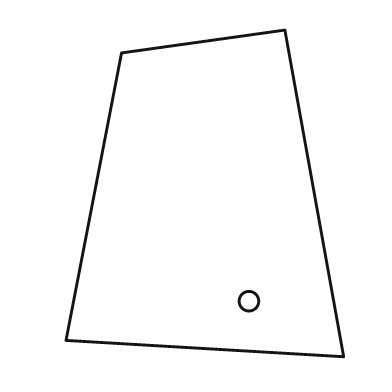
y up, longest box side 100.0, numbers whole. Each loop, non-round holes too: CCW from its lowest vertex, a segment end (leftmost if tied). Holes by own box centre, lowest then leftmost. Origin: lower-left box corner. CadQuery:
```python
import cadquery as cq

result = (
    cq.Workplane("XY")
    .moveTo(85.0, 0.0)
    .lineTo(67.0, 100.0)
    .lineTo(17.0, 93.0)
    .lineTo(0.0, 5.0)
    .close()
    .moveTo(56.0, 17.0)
    .circle(3.0)
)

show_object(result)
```